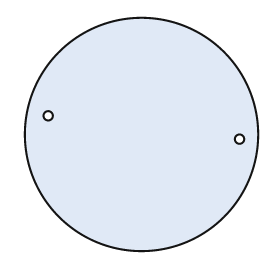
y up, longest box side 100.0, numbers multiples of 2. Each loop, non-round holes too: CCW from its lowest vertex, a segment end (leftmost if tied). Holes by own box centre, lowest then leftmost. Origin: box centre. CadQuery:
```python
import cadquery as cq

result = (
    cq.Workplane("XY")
    .moveTo(0.0, 0.0)
    .circle(50.0)
    .moveTo(42.0, -2.0)
    .circle(2.0)
    .moveTo(-40.0, 8.0)
    .circle(2.0)
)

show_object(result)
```